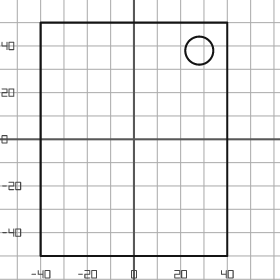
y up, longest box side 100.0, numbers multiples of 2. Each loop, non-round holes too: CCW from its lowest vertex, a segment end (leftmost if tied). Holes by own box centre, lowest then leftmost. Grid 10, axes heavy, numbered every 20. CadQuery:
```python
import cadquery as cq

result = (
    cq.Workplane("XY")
    .moveTo(-40.0, -50.0)
    .lineTo(40.0, -50.0)
    .lineTo(40.0, 50.0)
    .lineTo(-40.0, 50.0)
    .close()
    .moveTo(28.0, 38.0)
    .circle(6.0)
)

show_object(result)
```